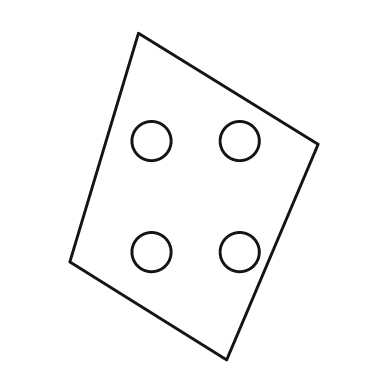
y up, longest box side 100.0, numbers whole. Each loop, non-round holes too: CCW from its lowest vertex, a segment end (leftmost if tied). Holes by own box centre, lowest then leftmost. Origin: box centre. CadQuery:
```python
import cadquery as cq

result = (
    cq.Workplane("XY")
    .moveTo(10.0, -50.0)
    .lineTo(38.0, 16.0)
    .lineTo(-17.0, 50.0)
    .lineTo(-38.0, -20.0)
    .close()
    .moveTo(-13.0, -17.0)
    .circle(6.0)
    .moveTo(14.0, -17.0)
    .circle(6.0)
    .moveTo(-13.0, 17.0)
    .circle(6.0)
    .moveTo(14.0, 17.0)
    .circle(6.0)
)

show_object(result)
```